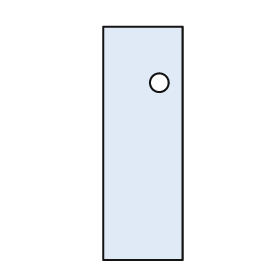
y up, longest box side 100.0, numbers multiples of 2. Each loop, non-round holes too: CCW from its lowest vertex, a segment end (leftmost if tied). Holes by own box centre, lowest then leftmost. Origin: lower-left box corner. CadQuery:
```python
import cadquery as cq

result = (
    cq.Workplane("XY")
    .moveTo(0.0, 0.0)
    .lineTo(34.0, 0.0)
    .lineTo(34.0, 100.0)
    .lineTo(0.0, 100.0)
    .close()
    .moveTo(24.0, 76.0)
    .circle(4.0)
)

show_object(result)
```